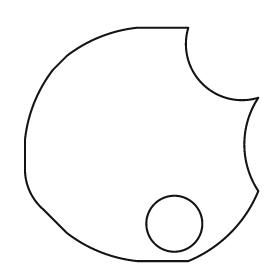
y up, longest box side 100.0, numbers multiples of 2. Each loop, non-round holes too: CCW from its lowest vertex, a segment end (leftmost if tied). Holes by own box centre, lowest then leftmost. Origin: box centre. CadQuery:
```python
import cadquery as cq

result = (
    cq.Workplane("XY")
    .moveTo(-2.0, -50.0)
    .lineTo(20.0, -50.0)
    .threePointArc((38.0, -38.0), (50.0, -20.0))
    .threePointArc((44.0, 0.0), (50.0, 20.0))
    .threePointArc((26.0, 26.0), (20.0, 50.0))
    .lineTo(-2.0, 50.0)
    .threePointArc((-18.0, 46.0), (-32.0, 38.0))
    .lineTo(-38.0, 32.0)
    .threePointArc((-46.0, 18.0), (-50.0, 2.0))
    .lineTo(-50.0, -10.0)
    .threePointArc((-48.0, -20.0), (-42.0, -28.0))
    .lineTo(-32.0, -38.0)
    .threePointArc((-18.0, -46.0), (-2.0, -50.0))
    .close()
    .moveTo(14.0, -34.0)
    .circle(12.0)
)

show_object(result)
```